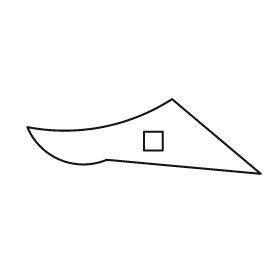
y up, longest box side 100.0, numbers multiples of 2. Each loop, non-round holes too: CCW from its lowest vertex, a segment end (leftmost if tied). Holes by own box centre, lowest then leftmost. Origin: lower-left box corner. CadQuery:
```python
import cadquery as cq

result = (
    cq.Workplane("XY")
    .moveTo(100.0, 0.0)
    .lineTo(62.0, 32.0)
    .threePointArc((32.0, 20.0), (0.0, 20.0))
    .threePointArc((14.0, 6.0), (34.0, 6.0))
    .close()
    .moveTo(50.0, 10.0)
    .lineTo(58.0, 10.0)
    .lineTo(58.0, 18.0)
    .lineTo(50.0, 18.0)
    .close()
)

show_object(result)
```